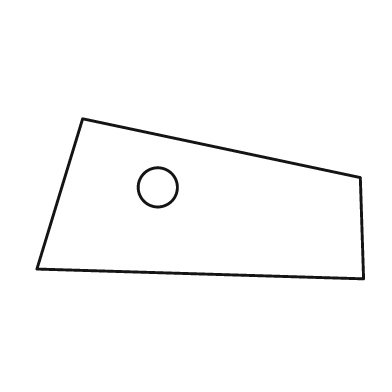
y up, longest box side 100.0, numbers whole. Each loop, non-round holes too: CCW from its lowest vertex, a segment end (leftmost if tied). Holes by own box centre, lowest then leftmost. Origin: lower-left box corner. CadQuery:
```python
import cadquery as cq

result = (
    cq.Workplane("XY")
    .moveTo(100.0, 0.0)
    .lineTo(99.0, 31.0)
    .lineTo(14.0, 49.0)
    .lineTo(0.0, 3.0)
    .close()
    .moveTo(37.0, 28.0)
    .circle(6.0)
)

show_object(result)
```